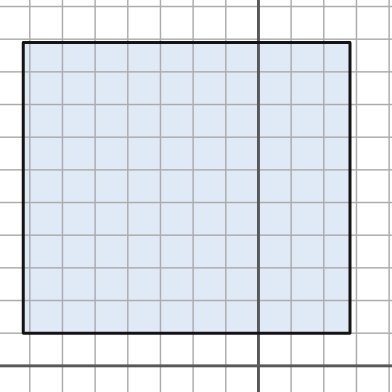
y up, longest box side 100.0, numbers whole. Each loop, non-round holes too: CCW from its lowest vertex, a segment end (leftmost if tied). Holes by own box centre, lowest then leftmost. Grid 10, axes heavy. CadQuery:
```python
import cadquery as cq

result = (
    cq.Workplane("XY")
    .moveTo(-72.0, 10.0)
    .lineTo(28.0, 10.0)
    .lineTo(28.0, 99.0)
    .lineTo(-72.0, 99.0)
    .close()
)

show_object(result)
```